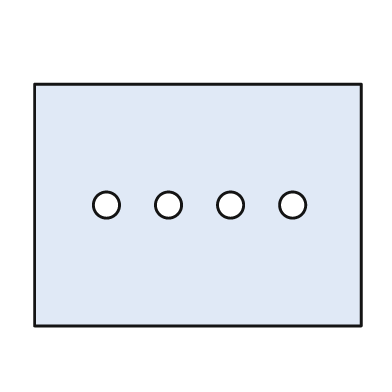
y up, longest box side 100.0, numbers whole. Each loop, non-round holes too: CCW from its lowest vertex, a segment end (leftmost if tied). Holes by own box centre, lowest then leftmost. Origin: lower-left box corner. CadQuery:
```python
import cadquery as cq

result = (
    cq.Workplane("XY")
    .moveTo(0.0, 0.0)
    .lineTo(100.0, 0.0)
    .lineTo(100.0, 74.0)
    .lineTo(0.0, 74.0)
    .close()
    .moveTo(22.0, 37.0)
    .circle(4.0)
    .moveTo(41.0, 37.0)
    .circle(4.0)
    .moveTo(60.0, 37.0)
    .circle(4.0)
    .moveTo(79.0, 37.0)
    .circle(4.0)
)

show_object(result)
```